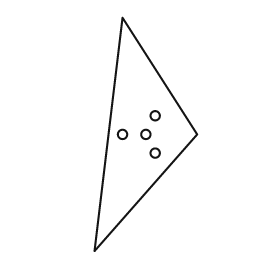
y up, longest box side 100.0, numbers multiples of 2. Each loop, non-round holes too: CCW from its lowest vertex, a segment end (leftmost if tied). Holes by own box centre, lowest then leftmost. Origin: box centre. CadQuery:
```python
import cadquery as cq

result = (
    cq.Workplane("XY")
    .moveTo(-22.0, -50.0)
    .lineTo(22.0, 0.0)
    .lineTo(-10.0, 50.0)
    .close()
    .moveTo(4.0, -8.0)
    .circle(2.0)
    .moveTo(-10.0, 0.0)
    .circle(2.0)
    .moveTo(0.0, 0.0)
    .circle(2.0)
    .moveTo(4.0, 8.0)
    .circle(2.0)
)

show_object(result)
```